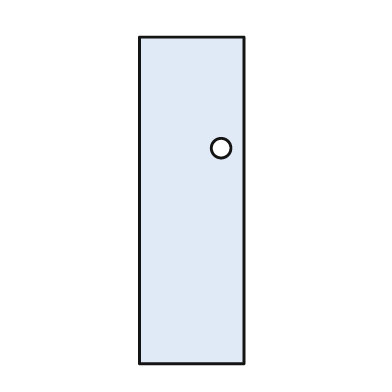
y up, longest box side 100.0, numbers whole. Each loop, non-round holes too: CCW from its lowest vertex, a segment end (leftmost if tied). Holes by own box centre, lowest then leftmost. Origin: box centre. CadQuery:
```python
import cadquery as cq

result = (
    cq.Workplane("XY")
    .moveTo(-16.0, -50.0)
    .lineTo(16.0, -50.0)
    .lineTo(16.0, 50.0)
    .lineTo(-16.0, 50.0)
    .close()
    .moveTo(9.0, 16.0)
    .circle(3.0)
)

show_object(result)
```